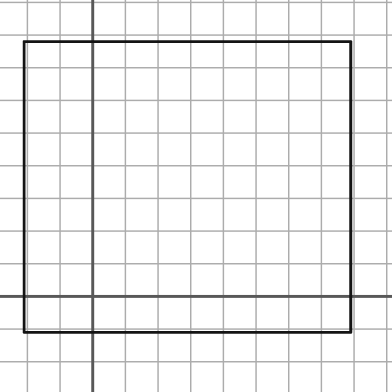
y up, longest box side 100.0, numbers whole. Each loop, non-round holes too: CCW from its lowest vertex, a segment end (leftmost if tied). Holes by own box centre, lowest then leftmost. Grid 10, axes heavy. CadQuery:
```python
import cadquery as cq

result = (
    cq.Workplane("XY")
    .moveTo(-21.0, -11.0)
    .lineTo(79.0, -11.0)
    .lineTo(79.0, 78.0)
    .lineTo(-21.0, 78.0)
    .close()
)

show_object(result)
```